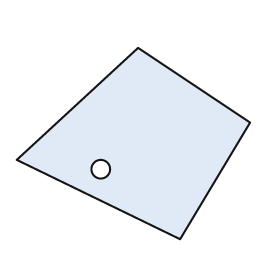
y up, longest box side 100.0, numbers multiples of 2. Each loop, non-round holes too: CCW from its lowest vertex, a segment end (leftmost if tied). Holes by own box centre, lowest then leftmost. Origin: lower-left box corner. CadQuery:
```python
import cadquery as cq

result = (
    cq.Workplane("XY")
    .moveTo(70.0, 0.0)
    .lineTo(100.0, 50.0)
    .lineTo(52.0, 82.0)
    .lineTo(0.0, 34.0)
    .close()
    .moveTo(36.0, 30.0)
    .circle(4.0)
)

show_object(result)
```